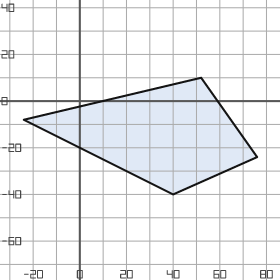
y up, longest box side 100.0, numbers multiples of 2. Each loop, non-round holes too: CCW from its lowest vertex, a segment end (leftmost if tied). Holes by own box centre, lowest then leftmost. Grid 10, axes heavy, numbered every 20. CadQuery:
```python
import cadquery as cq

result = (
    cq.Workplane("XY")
    .moveTo(40.0, -40.0)
    .lineTo(76.0, -24.0)
    .lineTo(52.0, 10.0)
    .lineTo(-24.0, -8.0)
    .close()
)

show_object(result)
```